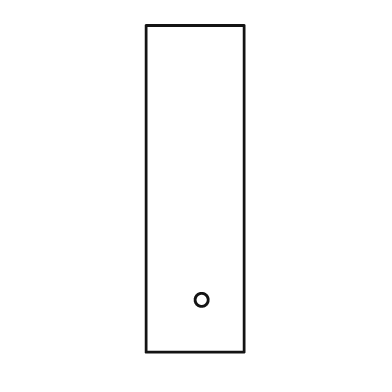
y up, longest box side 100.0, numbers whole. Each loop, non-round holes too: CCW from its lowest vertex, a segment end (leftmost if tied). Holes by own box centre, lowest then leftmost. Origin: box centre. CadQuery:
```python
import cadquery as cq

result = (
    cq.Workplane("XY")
    .moveTo(-15.0, -50.0)
    .lineTo(15.0, -50.0)
    .lineTo(15.0, 50.0)
    .lineTo(-15.0, 50.0)
    .close()
    .moveTo(2.0, -34.0)
    .circle(2.0)
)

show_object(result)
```